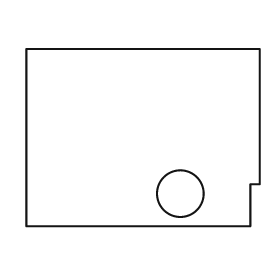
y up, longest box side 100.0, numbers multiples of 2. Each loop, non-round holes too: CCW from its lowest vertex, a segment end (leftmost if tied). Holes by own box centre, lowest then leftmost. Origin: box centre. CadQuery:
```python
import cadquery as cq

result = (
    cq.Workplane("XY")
    .moveTo(-50.0, -38.0)
    .lineTo(46.0, -38.0)
    .lineTo(46.0, -20.0)
    .lineTo(50.0, -20.0)
    .lineTo(50.0, 38.0)
    .lineTo(-50.0, 38.0)
    .close()
    .moveTo(16.0, -24.0)
    .circle(10.0)
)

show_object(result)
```